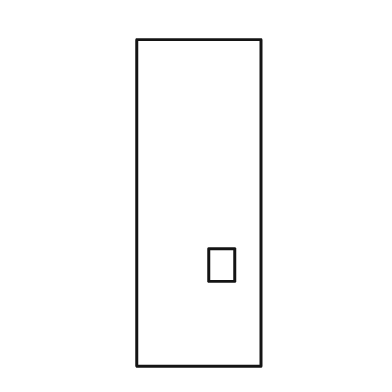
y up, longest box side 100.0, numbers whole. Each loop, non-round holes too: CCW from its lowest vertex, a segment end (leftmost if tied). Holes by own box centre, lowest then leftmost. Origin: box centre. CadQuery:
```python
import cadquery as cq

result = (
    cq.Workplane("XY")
    .moveTo(-19.0, -50.0)
    .lineTo(19.0, -50.0)
    .lineTo(19.0, 50.0)
    .lineTo(-19.0, 50.0)
    .close()
    .moveTo(3.0, -24.0)
    .lineTo(11.0, -24.0)
    .lineTo(11.0, -14.0)
    .lineTo(3.0, -14.0)
    .close()
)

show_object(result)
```